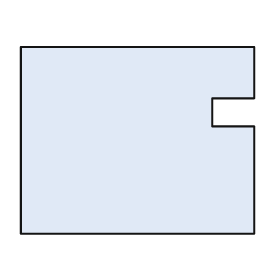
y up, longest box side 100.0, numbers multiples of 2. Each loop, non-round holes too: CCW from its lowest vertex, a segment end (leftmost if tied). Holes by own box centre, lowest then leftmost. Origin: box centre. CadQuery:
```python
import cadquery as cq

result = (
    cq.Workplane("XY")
    .moveTo(-50.0, -40.0)
    .lineTo(50.0, -40.0)
    .lineTo(50.0, 6.0)
    .lineTo(32.0, 6.0)
    .lineTo(32.0, 18.0)
    .lineTo(50.0, 18.0)
    .lineTo(50.0, 40.0)
    .lineTo(-50.0, 40.0)
    .close()
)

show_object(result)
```